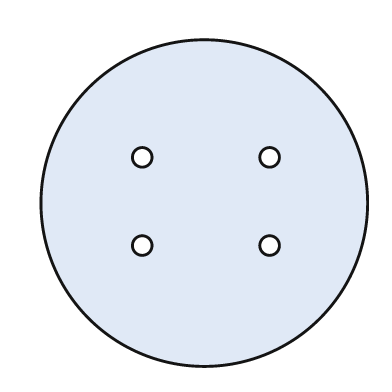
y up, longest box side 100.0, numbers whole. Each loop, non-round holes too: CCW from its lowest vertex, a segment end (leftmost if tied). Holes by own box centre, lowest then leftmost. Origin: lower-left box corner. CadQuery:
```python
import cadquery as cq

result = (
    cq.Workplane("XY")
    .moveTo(50.0, 50.0)
    .circle(50.0)
    .moveTo(31.0, 37.0)
    .circle(3.0)
    .moveTo(70.0, 37.0)
    .circle(3.0)
    .moveTo(31.0, 64.0)
    .circle(3.0)
    .moveTo(70.0, 64.0)
    .circle(3.0)
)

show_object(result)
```